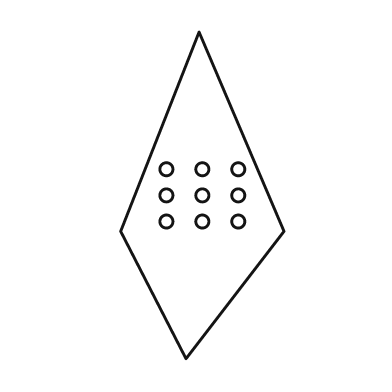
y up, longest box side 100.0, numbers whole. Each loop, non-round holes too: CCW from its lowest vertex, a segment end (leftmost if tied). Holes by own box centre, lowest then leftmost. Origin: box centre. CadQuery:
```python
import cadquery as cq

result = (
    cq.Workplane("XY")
    .moveTo(-5.0, -50.0)
    .lineTo(25.0, -11.0)
    .lineTo(-1.0, 50.0)
    .lineTo(-25.0, -11.0)
    .close()
    .moveTo(-11.0, -8.0)
    .circle(2.0)
    .moveTo(0.0, -8.0)
    .circle(2.0)
    .moveTo(11.0, -8.0)
    .circle(2.0)
    .moveTo(-11.0, 0.0)
    .circle(2.0)
    .moveTo(0.0, 0.0)
    .circle(2.0)
    .moveTo(11.0, 0.0)
    .circle(2.0)
    .moveTo(-11.0, 8.0)
    .circle(2.0)
    .moveTo(0.0, 8.0)
    .circle(2.0)
    .moveTo(11.0, 8.0)
    .circle(2.0)
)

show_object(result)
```